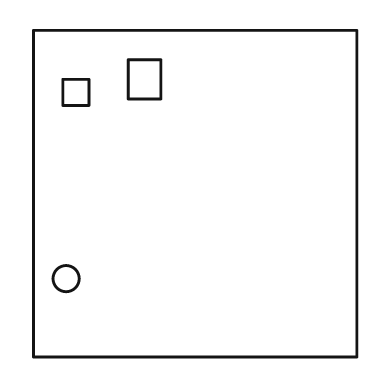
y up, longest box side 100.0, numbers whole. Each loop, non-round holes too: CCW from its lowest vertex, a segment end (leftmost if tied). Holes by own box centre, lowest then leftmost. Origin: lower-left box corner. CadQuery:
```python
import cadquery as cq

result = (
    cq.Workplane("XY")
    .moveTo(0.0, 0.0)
    .lineTo(99.0, 0.0)
    .lineTo(99.0, 100.0)
    .lineTo(0.0, 100.0)
    .close()
    .moveTo(10.0, 24.0)
    .circle(4.0)
    .moveTo(9.0, 77.0)
    .lineTo(17.0, 77.0)
    .lineTo(17.0, 85.0)
    .lineTo(9.0, 85.0)
    .close()
    .moveTo(29.0, 79.0)
    .lineTo(39.0, 79.0)
    .lineTo(39.0, 91.0)
    .lineTo(29.0, 91.0)
    .close()
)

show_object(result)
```